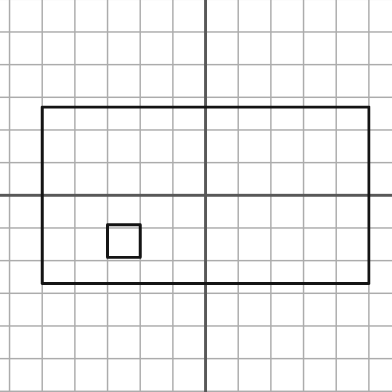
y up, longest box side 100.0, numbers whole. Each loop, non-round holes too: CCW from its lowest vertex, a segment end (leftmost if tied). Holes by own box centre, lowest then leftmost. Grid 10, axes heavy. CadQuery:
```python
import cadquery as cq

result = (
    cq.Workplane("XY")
    .moveTo(-50.0, -27.0)
    .lineTo(50.0, -27.0)
    .lineTo(50.0, 27.0)
    .lineTo(-50.0, 27.0)
    .close()
    .moveTo(-30.0, -19.0)
    .lineTo(-20.0, -19.0)
    .lineTo(-20.0, -9.0)
    .lineTo(-30.0, -9.0)
    .close()
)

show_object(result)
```